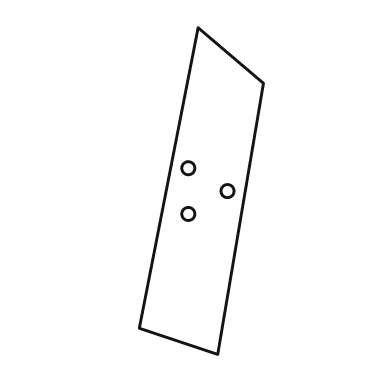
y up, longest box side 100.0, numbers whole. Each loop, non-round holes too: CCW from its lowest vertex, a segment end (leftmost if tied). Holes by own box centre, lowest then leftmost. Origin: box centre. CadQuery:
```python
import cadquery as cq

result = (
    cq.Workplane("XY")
    .moveTo(5.0, -50.0)
    .lineTo(19.0, 33.0)
    .lineTo(-1.0, 50.0)
    .lineTo(-19.0, -42.0)
    .close()
    .moveTo(-4.0, -7.0)
    .circle(2.0)
    .moveTo(8.0, 0.0)
    .circle(2.0)
    .moveTo(-4.0, 7.0)
    .circle(2.0)
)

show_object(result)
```